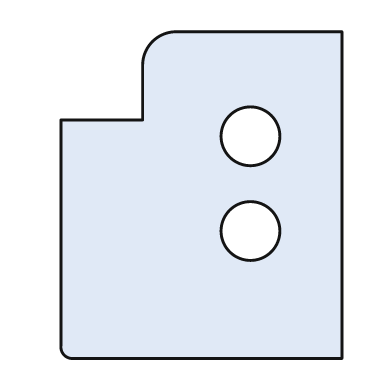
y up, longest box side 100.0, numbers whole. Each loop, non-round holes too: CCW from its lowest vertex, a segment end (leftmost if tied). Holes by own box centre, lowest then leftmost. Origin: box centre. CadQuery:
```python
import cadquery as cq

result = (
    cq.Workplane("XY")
    .moveTo(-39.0, -50.0)
    .lineTo(43.0, -50.0)
    .lineTo(43.0, 50.0)
    .lineTo(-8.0, 50.0)
    .threePointArc((-15.0, 47.0), (-18.0, 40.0))
    .lineTo(-18.0, 23.0)
    .lineTo(-43.0, 23.0)
    .lineTo(-43.0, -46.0)
    .threePointArc((-42.0, -49.0), (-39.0, -50.0))
    .close()
    .moveTo(15.0, -11.0)
    .circle(9.0)
    .moveTo(15.0, 18.0)
    .circle(9.0)
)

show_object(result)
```